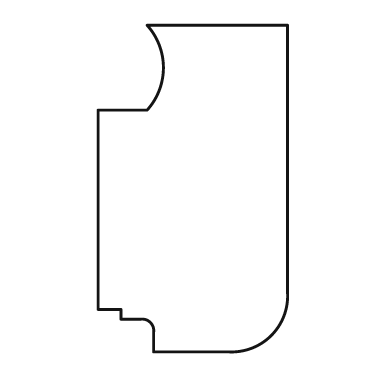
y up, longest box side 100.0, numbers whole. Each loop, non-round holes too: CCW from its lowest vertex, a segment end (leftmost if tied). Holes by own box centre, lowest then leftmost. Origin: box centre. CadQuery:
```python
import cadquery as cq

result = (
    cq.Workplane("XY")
    .moveTo(-12.0, -50.0)
    .lineTo(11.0, -50.0)
    .threePointArc((24.0, -45.0), (29.0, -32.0))
    .lineTo(29.0, 50.0)
    .lineTo(-14.0, 50.0)
    .threePointArc((-9.0, 37.0), (-14.0, 24.0))
    .lineTo(-29.0, 24.0)
    .lineTo(-29.0, -37.0)
    .lineTo(-22.0, -37.0)
    .lineTo(-22.0, -40.0)
    .lineTo(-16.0, -40.0)
    .threePointArc((-13.0, -41.0), (-12.0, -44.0))
    .close()
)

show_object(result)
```